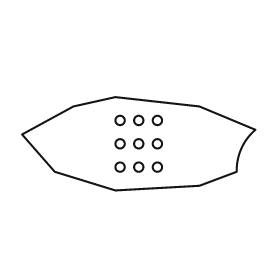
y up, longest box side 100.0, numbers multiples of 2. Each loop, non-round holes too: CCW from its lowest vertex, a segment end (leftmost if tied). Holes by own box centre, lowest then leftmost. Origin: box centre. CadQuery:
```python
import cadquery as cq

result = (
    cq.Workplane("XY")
    .moveTo(-10.0, -20.0)
    .lineTo(26.0, -18.0)
    .lineTo(42.0, -12.0)
    .threePointArc((44.0, -2.0), (50.0, 6.0))
    .lineTo(26.0, 16.0)
    .lineTo(-10.0, 20.0)
    .lineTo(-28.0, 16.0)
    .lineTo(-50.0, 4.0)
    .lineTo(-36.0, -12.0)
    .close()
    .moveTo(-8.0, -10.0)
    .circle(2.0)
    .moveTo(0.0, -10.0)
    .circle(2.0)
    .moveTo(8.0, -10.0)
    .circle(2.0)
    .moveTo(-8.0, 0.0)
    .circle(2.0)
    .moveTo(0.0, 0.0)
    .circle(2.0)
    .moveTo(8.0, 0.0)
    .circle(2.0)
    .moveTo(-8.0, 10.0)
    .circle(2.0)
    .moveTo(0.0, 10.0)
    .circle(2.0)
    .moveTo(8.0, 10.0)
    .circle(2.0)
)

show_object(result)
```